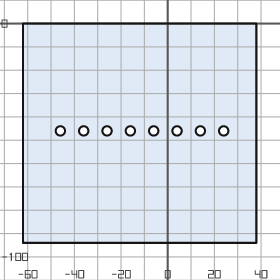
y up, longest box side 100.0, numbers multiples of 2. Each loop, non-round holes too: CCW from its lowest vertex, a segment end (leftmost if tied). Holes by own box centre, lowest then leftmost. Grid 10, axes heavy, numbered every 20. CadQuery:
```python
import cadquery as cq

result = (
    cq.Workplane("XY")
    .moveTo(-62.0, -94.0)
    .lineTo(38.0, -94.0)
    .lineTo(38.0, 0.0)
    .lineTo(-62.0, 0.0)
    .close()
    .moveTo(-46.0, -46.0)
    .circle(2.0)
    .moveTo(-36.0, -46.0)
    .circle(2.0)
    .moveTo(-26.0, -46.0)
    .circle(2.0)
    .moveTo(-16.0, -46.0)
    .circle(2.0)
    .moveTo(-6.0, -46.0)
    .circle(2.0)
    .moveTo(4.0, -46.0)
    .circle(2.0)
    .moveTo(14.0, -46.0)
    .circle(2.0)
    .moveTo(24.0, -46.0)
    .circle(2.0)
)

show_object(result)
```